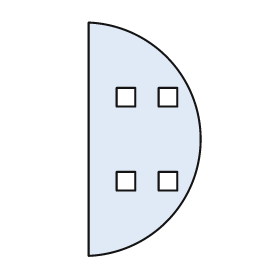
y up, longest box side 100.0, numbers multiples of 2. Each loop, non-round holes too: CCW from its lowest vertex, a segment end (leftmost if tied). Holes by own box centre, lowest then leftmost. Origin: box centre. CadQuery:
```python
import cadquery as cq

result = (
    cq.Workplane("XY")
    .moveTo(-24.0, -50.0)
    .threePointArc((24.0, 0.0), (-24.0, 50.0))
    .close()
    .moveTo(-12.0, -22.0)
    .lineTo(-4.0, -22.0)
    .lineTo(-4.0, -14.0)
    .lineTo(-12.0, -14.0)
    .close()
    .moveTo(6.0, -22.0)
    .lineTo(14.0, -22.0)
    .lineTo(14.0, -14.0)
    .lineTo(6.0, -14.0)
    .close()
    .moveTo(-12.0, 14.0)
    .lineTo(-4.0, 14.0)
    .lineTo(-4.0, 22.0)
    .lineTo(-12.0, 22.0)
    .close()
    .moveTo(6.0, 14.0)
    .lineTo(14.0, 14.0)
    .lineTo(14.0, 22.0)
    .lineTo(6.0, 22.0)
    .close()
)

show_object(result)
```